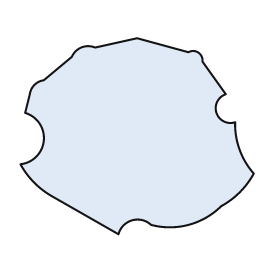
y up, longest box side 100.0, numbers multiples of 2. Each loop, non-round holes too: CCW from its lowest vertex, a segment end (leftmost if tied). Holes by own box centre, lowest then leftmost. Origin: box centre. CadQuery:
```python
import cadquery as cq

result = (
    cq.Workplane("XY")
    .moveTo(-8.0, -42.0)
    .threePointArc((-2.0, -36.0), (6.0, -38.0))
    .threePointArc((22.0, -38.0), (36.0, -30.0))
    .threePointArc((44.0, -24.0), (50.0, -16.0))
    .threePointArc((44.0, -6.0), (42.0, 6.0))
    .threePointArc((34.0, 10.0), (38.0, 18.0))
    .lineTo(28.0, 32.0)
    .threePointArc((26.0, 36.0), (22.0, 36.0))
    .lineTo(0.0, 42.0)
    .lineTo(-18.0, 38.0)
    .threePointArc((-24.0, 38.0), (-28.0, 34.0))
    .lineTo(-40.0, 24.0)
    .threePointArc((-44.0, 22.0), (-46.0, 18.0))
    .lineTo(-48.0, 10.0)
    .threePointArc((-40.0, -2.0), (-50.0, -12.0))
    .threePointArc((-44.0, -20.0), (-36.0, -26.0))
    .close()
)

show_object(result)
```